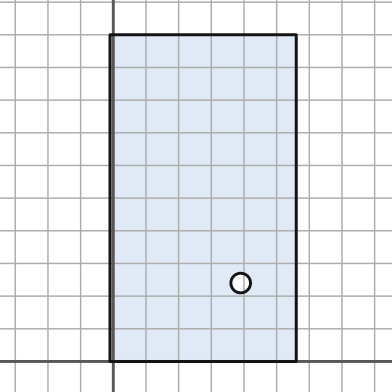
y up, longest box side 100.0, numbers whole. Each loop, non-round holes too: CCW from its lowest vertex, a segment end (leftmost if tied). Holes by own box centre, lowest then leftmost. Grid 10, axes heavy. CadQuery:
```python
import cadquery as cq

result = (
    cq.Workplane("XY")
    .moveTo(-1.0, 0.0)
    .lineTo(56.0, 0.0)
    .lineTo(56.0, 100.0)
    .lineTo(-1.0, 100.0)
    .close()
    .moveTo(39.0, 24.0)
    .circle(3.0)
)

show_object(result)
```